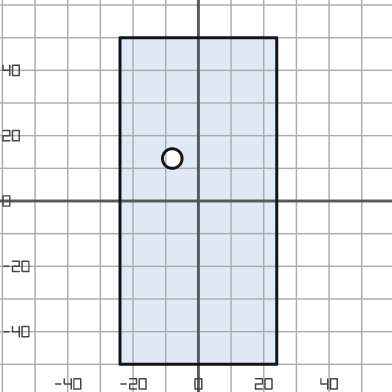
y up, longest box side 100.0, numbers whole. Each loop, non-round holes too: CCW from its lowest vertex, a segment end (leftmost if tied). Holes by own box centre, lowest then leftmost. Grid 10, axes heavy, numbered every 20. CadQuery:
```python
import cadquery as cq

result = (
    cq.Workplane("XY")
    .moveTo(-24.0, -50.0)
    .lineTo(24.0, -50.0)
    .lineTo(24.0, 50.0)
    .lineTo(-24.0, 50.0)
    .close()
    .moveTo(-8.0, 13.0)
    .circle(3.0)
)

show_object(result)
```